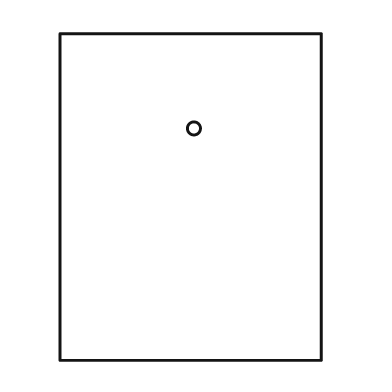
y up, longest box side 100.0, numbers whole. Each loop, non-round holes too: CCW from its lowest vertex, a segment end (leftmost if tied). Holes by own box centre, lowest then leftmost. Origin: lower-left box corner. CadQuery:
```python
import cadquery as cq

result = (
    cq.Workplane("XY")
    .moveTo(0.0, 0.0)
    .lineTo(80.0, 0.0)
    .lineTo(80.0, 100.0)
    .lineTo(0.0, 100.0)
    .close()
    .moveTo(41.0, 71.0)
    .circle(2.0)
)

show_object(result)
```